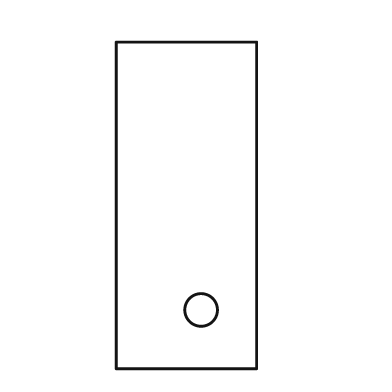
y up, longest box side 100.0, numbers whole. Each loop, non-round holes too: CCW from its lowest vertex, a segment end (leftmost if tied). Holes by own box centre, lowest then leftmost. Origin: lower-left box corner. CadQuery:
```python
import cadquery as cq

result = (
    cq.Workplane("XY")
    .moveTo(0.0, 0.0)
    .lineTo(43.0, 0.0)
    .lineTo(43.0, 100.0)
    .lineTo(0.0, 100.0)
    .close()
    .moveTo(26.0, 18.0)
    .circle(5.0)
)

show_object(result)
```